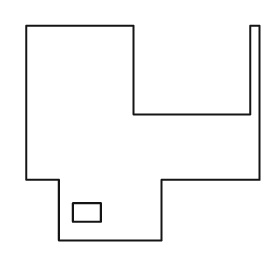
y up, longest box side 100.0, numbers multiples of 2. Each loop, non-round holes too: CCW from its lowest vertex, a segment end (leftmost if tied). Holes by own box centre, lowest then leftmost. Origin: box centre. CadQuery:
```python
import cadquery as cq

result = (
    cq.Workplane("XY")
    .moveTo(-36.0, -46.0)
    .lineTo(8.0, -46.0)
    .lineTo(8.0, -20.0)
    .lineTo(50.0, -20.0)
    .lineTo(50.0, 46.0)
    .lineTo(46.0, 46.0)
    .lineTo(46.0, 8.0)
    .lineTo(-4.0, 8.0)
    .lineTo(-4.0, 46.0)
    .lineTo(-50.0, 46.0)
    .lineTo(-50.0, -20.0)
    .lineTo(-36.0, -20.0)
    .close()
    .moveTo(-30.0, -38.0)
    .lineTo(-18.0, -38.0)
    .lineTo(-18.0, -30.0)
    .lineTo(-30.0, -30.0)
    .close()
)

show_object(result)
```